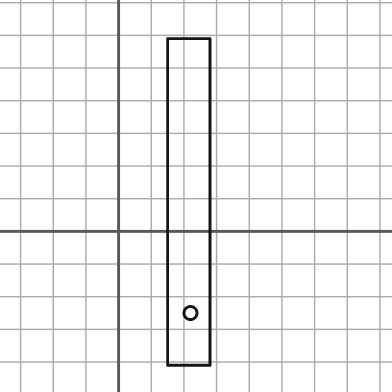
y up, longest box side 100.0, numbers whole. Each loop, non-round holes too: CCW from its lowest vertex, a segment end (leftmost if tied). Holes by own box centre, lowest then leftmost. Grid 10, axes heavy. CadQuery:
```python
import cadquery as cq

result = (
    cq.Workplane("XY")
    .moveTo(15.0, -41.0)
    .lineTo(28.0, -41.0)
    .lineTo(28.0, 59.0)
    .lineTo(15.0, 59.0)
    .close()
    .moveTo(22.0, -25.0)
    .circle(2.0)
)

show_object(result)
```